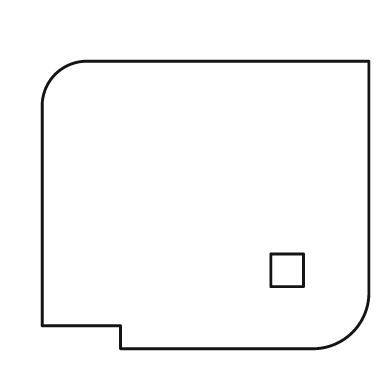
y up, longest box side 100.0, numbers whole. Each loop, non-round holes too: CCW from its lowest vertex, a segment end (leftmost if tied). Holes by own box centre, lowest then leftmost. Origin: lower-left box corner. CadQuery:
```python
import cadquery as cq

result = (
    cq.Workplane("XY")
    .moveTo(24.0, 0.0)
    .lineTo(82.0, 0.0)
    .threePointArc((95.0, 5.0), (100.0, 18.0))
    .lineTo(100.0, 88.0)
    .lineTo(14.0, 88.0)
    .threePointArc((4.0, 84.0), (0.0, 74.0))
    .lineTo(0.0, 7.0)
    .lineTo(24.0, 7.0)
    .close()
    .moveTo(70.0, 19.0)
    .lineTo(80.0, 19.0)
    .lineTo(80.0, 29.0)
    .lineTo(70.0, 29.0)
    .close()
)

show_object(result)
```